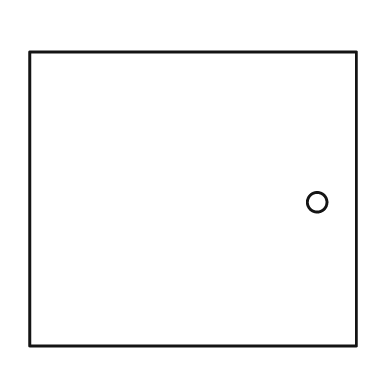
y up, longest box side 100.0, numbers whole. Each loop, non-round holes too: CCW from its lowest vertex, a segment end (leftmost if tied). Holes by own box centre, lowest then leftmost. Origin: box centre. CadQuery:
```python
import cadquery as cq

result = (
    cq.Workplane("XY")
    .moveTo(-50.0, -45.0)
    .lineTo(50.0, -45.0)
    .lineTo(50.0, 45.0)
    .lineTo(-50.0, 45.0)
    .close()
    .moveTo(38.0, -1.0)
    .circle(3.0)
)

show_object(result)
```